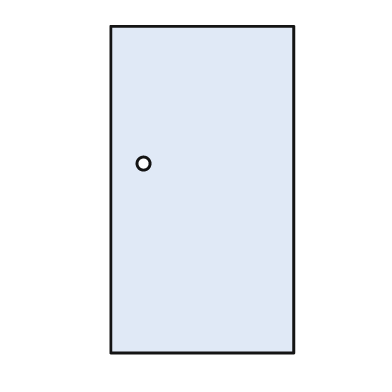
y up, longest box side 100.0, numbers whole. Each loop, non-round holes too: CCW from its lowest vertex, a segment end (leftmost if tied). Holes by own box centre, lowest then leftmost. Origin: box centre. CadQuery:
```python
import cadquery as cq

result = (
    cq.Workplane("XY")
    .moveTo(-28.0, -50.0)
    .lineTo(28.0, -50.0)
    .lineTo(28.0, 50.0)
    .lineTo(-28.0, 50.0)
    .close()
    .moveTo(-18.0, 8.0)
    .circle(2.0)
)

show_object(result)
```